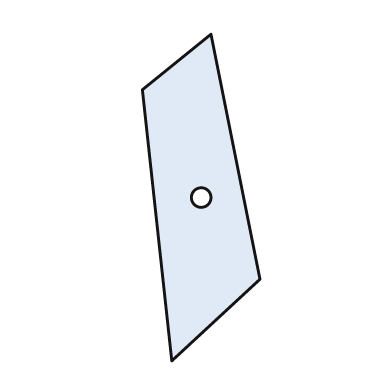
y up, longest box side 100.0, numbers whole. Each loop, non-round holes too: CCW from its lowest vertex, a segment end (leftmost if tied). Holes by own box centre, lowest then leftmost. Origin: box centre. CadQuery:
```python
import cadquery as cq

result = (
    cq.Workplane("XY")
    .moveTo(-9.0, -50.0)
    .lineTo(18.0, -25.0)
    .lineTo(3.0, 50.0)
    .lineTo(-18.0, 33.0)
    .close()
    .moveTo(0.0, 0.0)
    .circle(3.0)
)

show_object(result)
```